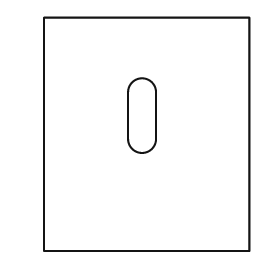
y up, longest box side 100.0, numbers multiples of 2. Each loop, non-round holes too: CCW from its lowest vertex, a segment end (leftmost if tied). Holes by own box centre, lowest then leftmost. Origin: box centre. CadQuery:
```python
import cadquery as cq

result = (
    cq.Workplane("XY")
    .moveTo(-44.0, -50.0)
    .lineTo(44.0, -50.0)
    .lineTo(44.0, 50.0)
    .lineTo(-44.0, 50.0)
    .close()
    .moveTo(-8.0, -2.0)
    .threePointArc((-2.0, -8.0), (4.0, -2.0))
    .lineTo(4.0, 18.0)
    .threePointArc((-2.0, 24.0), (-8.0, 18.0))
    .close()
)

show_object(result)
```